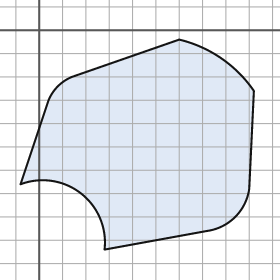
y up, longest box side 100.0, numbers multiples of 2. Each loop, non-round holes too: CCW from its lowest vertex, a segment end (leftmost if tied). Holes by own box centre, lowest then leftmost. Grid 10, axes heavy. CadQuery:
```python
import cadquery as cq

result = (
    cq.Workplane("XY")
    .moveTo(28.0, -94.0)
    .lineTo(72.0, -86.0)
    .threePointArc((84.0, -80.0), (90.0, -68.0))
    .lineTo(92.0, -26.0)
    .threePointArc((78.0, -12.0), (60.0, -4.0))
    .lineTo(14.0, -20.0)
    .threePointArc((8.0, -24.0), (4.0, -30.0))
    .lineTo(-8.0, -66.0)
    .threePointArc((18.0, -70.0), (28.0, -94.0))
    .close()
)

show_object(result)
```